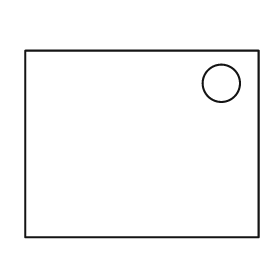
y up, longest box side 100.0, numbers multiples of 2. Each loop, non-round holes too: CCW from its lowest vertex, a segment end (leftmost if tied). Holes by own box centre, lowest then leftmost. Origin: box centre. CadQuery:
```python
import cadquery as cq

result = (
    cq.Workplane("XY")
    .moveTo(-50.0, -40.0)
    .lineTo(50.0, -40.0)
    .lineTo(50.0, 40.0)
    .lineTo(-50.0, 40.0)
    .close()
    .moveTo(34.0, 26.0)
    .circle(8.0)
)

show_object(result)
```